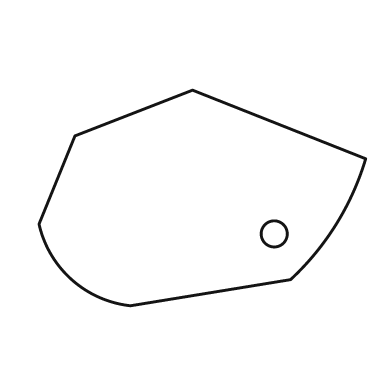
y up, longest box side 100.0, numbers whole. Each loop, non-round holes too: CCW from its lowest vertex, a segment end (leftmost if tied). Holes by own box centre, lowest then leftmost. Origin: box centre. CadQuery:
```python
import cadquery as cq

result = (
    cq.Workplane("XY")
    .moveTo(-22.0, -33.0)
    .lineTo(27.0, -25.0)
    .threePointArc((41.0, -8.0), (50.0, 12.0))
    .lineTo(-3.0, 33.0)
    .lineTo(-39.0, 19.0)
    .lineTo(-50.0, -8.0)
    .threePointArc((-40.0, -25.0), (-22.0, -33.0))
    .close()
    .moveTo(22.0, -11.0)
    .circle(4.0)
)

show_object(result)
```